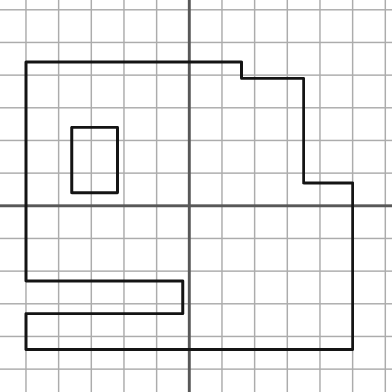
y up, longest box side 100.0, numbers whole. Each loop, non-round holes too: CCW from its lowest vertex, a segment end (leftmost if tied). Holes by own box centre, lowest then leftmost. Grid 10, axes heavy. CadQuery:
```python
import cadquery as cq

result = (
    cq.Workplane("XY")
    .moveTo(-50.0, -44.0)
    .lineTo(50.0, -44.0)
    .lineTo(50.0, 7.0)
    .lineTo(35.0, 7.0)
    .lineTo(35.0, 39.0)
    .lineTo(16.0, 39.0)
    .lineTo(16.0, 44.0)
    .lineTo(-50.0, 44.0)
    .lineTo(-50.0, -23.0)
    .lineTo(-2.0, -23.0)
    .lineTo(-2.0, -33.0)
    .lineTo(-50.0, -33.0)
    .close()
    .moveTo(-36.0, 4.0)
    .lineTo(-22.0, 4.0)
    .lineTo(-22.0, 24.0)
    .lineTo(-36.0, 24.0)
    .close()
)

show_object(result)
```